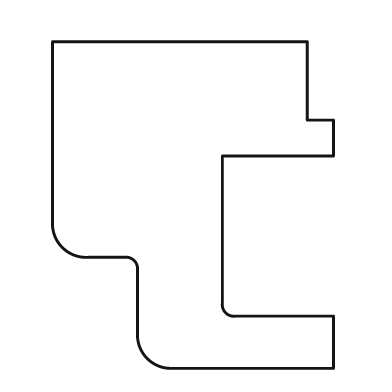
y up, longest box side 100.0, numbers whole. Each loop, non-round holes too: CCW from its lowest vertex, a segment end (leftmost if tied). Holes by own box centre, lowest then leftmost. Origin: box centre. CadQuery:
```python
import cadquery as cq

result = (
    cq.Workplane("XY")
    .moveTo(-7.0, -50.0)
    .lineTo(43.0, -50.0)
    .lineTo(43.0, -34.0)
    .lineTo(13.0, -34.0)
    .threePointArc((10.0, -33.0), (9.0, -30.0))
    .lineTo(9.0, 15.0)
    .lineTo(43.0, 15.0)
    .lineTo(43.0, 26.0)
    .lineTo(35.0, 26.0)
    .lineTo(35.0, 50.0)
    .lineTo(-43.0, 50.0)
    .lineTo(-43.0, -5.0)
    .threePointArc((-40.0, -13.0), (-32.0, -16.0))
    .lineTo(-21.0, -16.0)
    .threePointArc((-18.0, -17.0), (-17.0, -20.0))
    .lineTo(-17.0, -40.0)
    .threePointArc((-14.0, -47.0), (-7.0, -50.0))
    .close()
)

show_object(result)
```